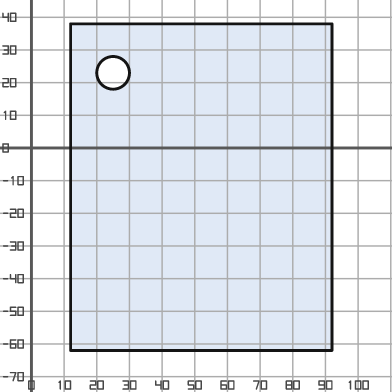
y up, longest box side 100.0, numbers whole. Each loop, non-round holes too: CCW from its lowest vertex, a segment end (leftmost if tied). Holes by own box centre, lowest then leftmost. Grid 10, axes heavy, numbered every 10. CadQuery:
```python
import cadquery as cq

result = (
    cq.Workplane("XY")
    .moveTo(12.0, -62.0)
    .lineTo(92.0, -62.0)
    .lineTo(92.0, 38.0)
    .lineTo(12.0, 38.0)
    .close()
    .moveTo(25.0, 23.0)
    .circle(5.0)
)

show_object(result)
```